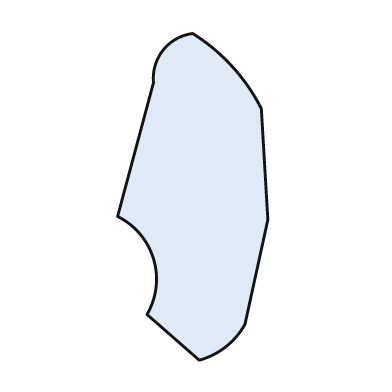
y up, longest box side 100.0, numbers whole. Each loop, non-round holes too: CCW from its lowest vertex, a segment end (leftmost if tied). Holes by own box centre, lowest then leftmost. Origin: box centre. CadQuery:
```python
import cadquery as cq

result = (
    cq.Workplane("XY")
    .moveTo(2.0, -50.0)
    .threePointArc((10.0, -46.0), (16.0, -39.0))
    .lineTo(23.0, -7.0)
    .lineTo(21.0, 27.0)
    .threePointArc((12.0, 40.0), (0.0, 50.0))
    .threePointArc((-9.0, 45.0), (-12.0, 35.0))
    .lineTo(-23.0, -6.0)
    .threePointArc((-12.0, -19.0), (-14.0, -36.0))
    .close()
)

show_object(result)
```